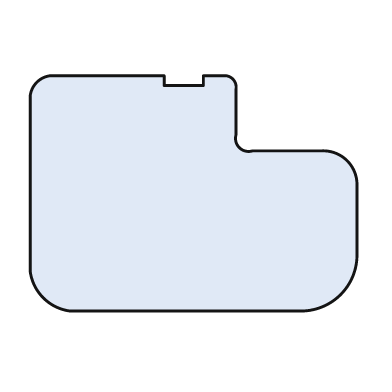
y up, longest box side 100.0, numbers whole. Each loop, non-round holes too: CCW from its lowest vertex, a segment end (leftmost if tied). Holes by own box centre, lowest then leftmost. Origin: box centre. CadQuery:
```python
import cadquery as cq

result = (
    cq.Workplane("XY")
    .moveTo(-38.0, -36.0)
    .lineTo(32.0, -36.0)
    .threePointArc((45.0, -31.0), (50.0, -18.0))
    .lineTo(50.0, 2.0)
    .threePointArc((47.0, 10.0), (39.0, 13.0))
    .lineTo(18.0, 13.0)
    .threePointArc((14.0, 14.0), (13.0, 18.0))
    .lineTo(13.0, 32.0)
    .threePointArc((12.0, 35.0), (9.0, 36.0))
    .lineTo(3.0, 36.0)
    .lineTo(3.0, 33.0)
    .lineTo(-9.0, 33.0)
    .lineTo(-9.0, 36.0)
    .lineTo(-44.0, 36.0)
    .threePointArc((-48.0, 34.0), (-50.0, 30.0))
    .lineTo(-50.0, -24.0)
    .threePointArc((-46.0, -32.0), (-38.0, -36.0))
    .close()
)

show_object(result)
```